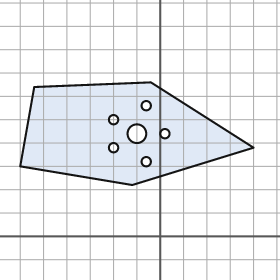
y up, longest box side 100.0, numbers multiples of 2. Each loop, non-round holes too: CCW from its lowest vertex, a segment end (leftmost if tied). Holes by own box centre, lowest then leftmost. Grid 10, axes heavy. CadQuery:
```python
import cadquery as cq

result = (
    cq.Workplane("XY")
    .moveTo(-12.0, 22.0)
    .lineTo(40.0, 38.0)
    .lineTo(-4.0, 66.0)
    .lineTo(-54.0, 64.0)
    .lineTo(-60.0, 30.0)
    .close()
    .moveTo(-6.0, 32.0)
    .circle(2.0)
    .moveTo(-20.0, 38.0)
    .circle(2.0)
    .moveTo(-10.0, 44.0)
    .circle(4.0)
    .moveTo(2.0, 44.0)
    .circle(2.0)
    .moveTo(-20.0, 50.0)
    .circle(2.0)
    .moveTo(-6.0, 56.0)
    .circle(2.0)
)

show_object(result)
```